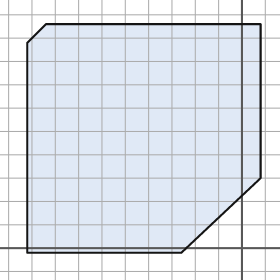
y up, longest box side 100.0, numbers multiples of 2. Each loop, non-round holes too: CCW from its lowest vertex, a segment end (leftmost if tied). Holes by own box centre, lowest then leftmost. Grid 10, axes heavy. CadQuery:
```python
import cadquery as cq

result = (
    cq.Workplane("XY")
    .moveTo(-92.0, -2.0)
    .lineTo(-26.0, -2.0)
    .lineTo(8.0, 30.0)
    .lineTo(8.0, 96.0)
    .lineTo(-84.0, 96.0)
    .lineTo(-92.0, 88.0)
    .close()
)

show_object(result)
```